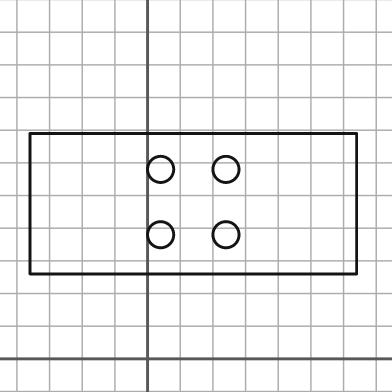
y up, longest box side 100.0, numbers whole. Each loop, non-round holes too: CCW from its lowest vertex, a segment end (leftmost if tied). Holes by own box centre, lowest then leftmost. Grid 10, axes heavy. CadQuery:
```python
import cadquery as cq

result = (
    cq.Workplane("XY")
    .moveTo(-36.0, 26.0)
    .lineTo(64.0, 26.0)
    .lineTo(64.0, 69.0)
    .lineTo(-36.0, 69.0)
    .close()
    .moveTo(4.0, 38.0)
    .circle(4.0)
    .moveTo(24.0, 38.0)
    .circle(4.0)
    .moveTo(4.0, 58.0)
    .circle(4.0)
    .moveTo(24.0, 58.0)
    .circle(4.0)
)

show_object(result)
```